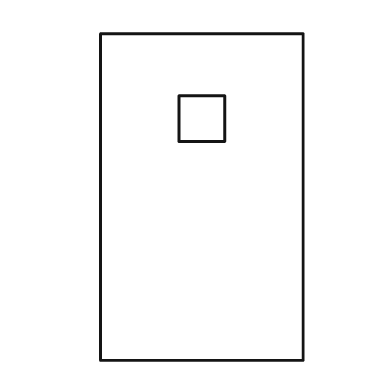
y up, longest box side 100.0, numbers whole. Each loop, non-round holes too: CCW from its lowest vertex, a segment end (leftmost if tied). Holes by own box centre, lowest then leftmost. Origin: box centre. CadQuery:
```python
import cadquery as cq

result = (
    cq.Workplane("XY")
    .moveTo(-31.0, -50.0)
    .lineTo(31.0, -50.0)
    .lineTo(31.0, 50.0)
    .lineTo(-31.0, 50.0)
    .close()
    .moveTo(-7.0, 17.0)
    .lineTo(7.0, 17.0)
    .lineTo(7.0, 31.0)
    .lineTo(-7.0, 31.0)
    .close()
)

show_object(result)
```